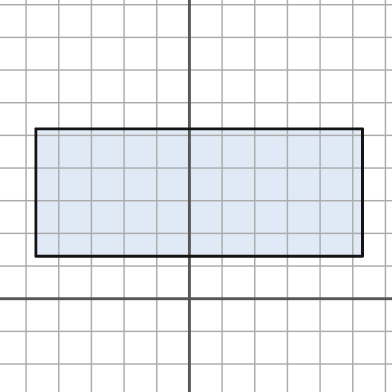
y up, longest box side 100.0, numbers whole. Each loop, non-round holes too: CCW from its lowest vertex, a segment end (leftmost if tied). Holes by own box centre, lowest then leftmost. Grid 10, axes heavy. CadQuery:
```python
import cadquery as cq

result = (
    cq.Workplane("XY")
    .moveTo(-47.0, 13.0)
    .lineTo(53.0, 13.0)
    .lineTo(53.0, 52.0)
    .lineTo(-47.0, 52.0)
    .close()
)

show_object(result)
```